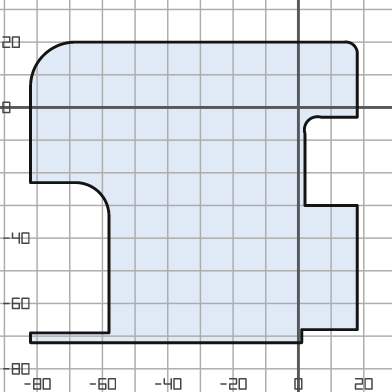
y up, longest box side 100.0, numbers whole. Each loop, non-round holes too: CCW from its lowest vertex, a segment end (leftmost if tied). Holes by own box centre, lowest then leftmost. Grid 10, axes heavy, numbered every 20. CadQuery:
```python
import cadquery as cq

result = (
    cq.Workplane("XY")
    .moveTo(-82.0, -72.0)
    .lineTo(1.0, -72.0)
    .lineTo(1.0, -68.0)
    .lineTo(18.0, -68.0)
    .lineTo(18.0, -30.0)
    .lineTo(2.0, -30.0)
    .lineTo(2.0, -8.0)
    .threePointArc((3.0, -4.0), (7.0, -3.0))
    .lineTo(18.0, -3.0)
    .lineTo(18.0, 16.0)
    .threePointArc((17.0, 19.0), (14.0, 20.0))
    .lineTo(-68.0, 20.0)
    .threePointArc((-78.0, 16.0), (-82.0, 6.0))
    .lineTo(-82.0, -23.0)
    .lineTo(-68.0, -23.0)
    .threePointArc((-61.0, -26.0), (-58.0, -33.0))
    .lineTo(-58.0, -69.0)
    .lineTo(-82.0, -69.0)
    .close()
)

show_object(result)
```